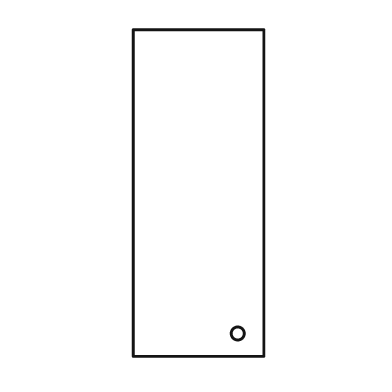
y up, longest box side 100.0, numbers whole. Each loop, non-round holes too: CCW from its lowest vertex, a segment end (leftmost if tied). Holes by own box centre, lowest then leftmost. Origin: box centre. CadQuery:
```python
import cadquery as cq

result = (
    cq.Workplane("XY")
    .moveTo(-20.0, -50.0)
    .lineTo(20.0, -50.0)
    .lineTo(20.0, 50.0)
    .lineTo(-20.0, 50.0)
    .close()
    .moveTo(12.0, -43.0)
    .circle(2.0)
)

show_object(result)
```